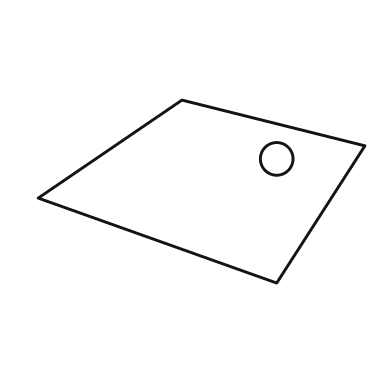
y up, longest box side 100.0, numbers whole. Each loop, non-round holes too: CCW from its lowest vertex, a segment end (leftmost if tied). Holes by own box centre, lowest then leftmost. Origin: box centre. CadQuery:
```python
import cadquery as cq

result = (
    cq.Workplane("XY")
    .moveTo(23.0, -28.0)
    .lineTo(50.0, 14.0)
    .lineTo(-6.0, 28.0)
    .lineTo(-50.0, -2.0)
    .close()
    .moveTo(23.0, 10.0)
    .circle(5.0)
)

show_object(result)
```